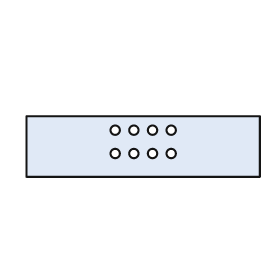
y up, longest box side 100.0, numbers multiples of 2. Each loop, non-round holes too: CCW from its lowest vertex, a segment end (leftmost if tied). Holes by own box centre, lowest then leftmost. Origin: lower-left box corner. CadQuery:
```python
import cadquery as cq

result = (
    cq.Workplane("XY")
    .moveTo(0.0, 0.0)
    .lineTo(100.0, 0.0)
    .lineTo(100.0, 26.0)
    .lineTo(0.0, 26.0)
    .close()
    .moveTo(38.0, 10.0)
    .circle(2.0)
    .moveTo(46.0, 10.0)
    .circle(2.0)
    .moveTo(54.0, 10.0)
    .circle(2.0)
    .moveTo(62.0, 10.0)
    .circle(2.0)
    .moveTo(38.0, 20.0)
    .circle(2.0)
    .moveTo(46.0, 20.0)
    .circle(2.0)
    .moveTo(54.0, 20.0)
    .circle(2.0)
    .moveTo(62.0, 20.0)
    .circle(2.0)
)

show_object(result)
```